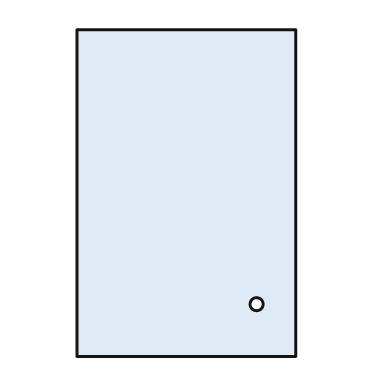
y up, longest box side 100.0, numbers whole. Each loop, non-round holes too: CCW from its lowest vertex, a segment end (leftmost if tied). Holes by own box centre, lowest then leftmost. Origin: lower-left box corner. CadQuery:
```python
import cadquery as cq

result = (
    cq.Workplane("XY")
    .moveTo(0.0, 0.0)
    .lineTo(67.0, 0.0)
    .lineTo(67.0, 100.0)
    .lineTo(0.0, 100.0)
    .close()
    .moveTo(55.0, 16.0)
    .circle(2.0)
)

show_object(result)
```